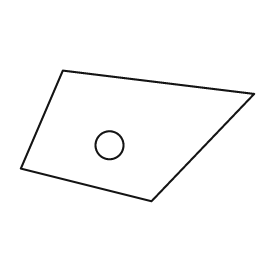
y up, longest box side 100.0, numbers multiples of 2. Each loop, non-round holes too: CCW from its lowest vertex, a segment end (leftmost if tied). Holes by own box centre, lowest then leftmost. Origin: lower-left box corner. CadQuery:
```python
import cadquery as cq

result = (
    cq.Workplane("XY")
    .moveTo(56.0, 0.0)
    .lineTo(100.0, 46.0)
    .lineTo(18.0, 56.0)
    .lineTo(0.0, 14.0)
    .close()
    .moveTo(38.0, 24.0)
    .circle(6.0)
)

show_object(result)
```